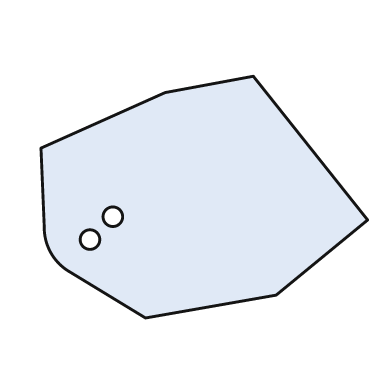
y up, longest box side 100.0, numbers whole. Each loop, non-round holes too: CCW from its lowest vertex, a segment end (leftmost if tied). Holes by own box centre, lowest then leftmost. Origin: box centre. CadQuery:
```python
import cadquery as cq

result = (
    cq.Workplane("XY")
    .moveTo(-18.0, -37.0)
    .lineTo(22.0, -30.0)
    .lineTo(50.0, -7.0)
    .lineTo(15.0, 37.0)
    .lineTo(-12.0, 32.0)
    .lineTo(-50.0, 15.0)
    .lineTo(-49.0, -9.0)
    .threePointArc((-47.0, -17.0), (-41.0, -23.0))
    .close()
    .moveTo(-35.0, -13.0)
    .circle(3.0)
    .moveTo(-28.0, -6.0)
    .circle(3.0)
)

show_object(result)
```